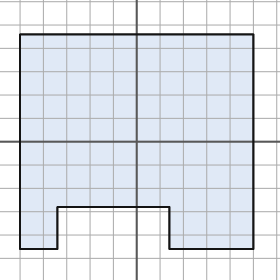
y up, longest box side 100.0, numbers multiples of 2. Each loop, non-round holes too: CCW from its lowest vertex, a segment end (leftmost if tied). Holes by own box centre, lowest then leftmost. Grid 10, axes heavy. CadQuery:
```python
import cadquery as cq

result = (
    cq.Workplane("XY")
    .moveTo(-50.0, -46.0)
    .lineTo(-34.0, -46.0)
    .lineTo(-34.0, -28.0)
    .lineTo(14.0, -28.0)
    .lineTo(14.0, -46.0)
    .lineTo(50.0, -46.0)
    .lineTo(50.0, 46.0)
    .lineTo(-50.0, 46.0)
    .close()
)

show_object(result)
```